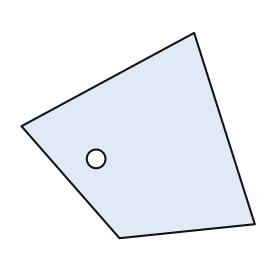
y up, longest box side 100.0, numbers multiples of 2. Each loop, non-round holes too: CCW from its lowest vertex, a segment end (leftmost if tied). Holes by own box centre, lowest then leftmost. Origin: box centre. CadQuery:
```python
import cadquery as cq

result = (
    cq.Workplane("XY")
    .moveTo(-8.0, -44.0)
    .lineTo(50.0, -38.0)
    .lineTo(24.0, 44.0)
    .lineTo(-50.0, 4.0)
    .close()
    .moveTo(-18.0, -10.0)
    .circle(4.0)
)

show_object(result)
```